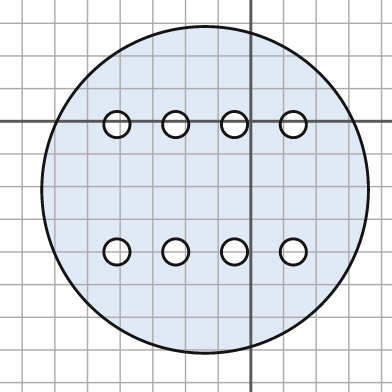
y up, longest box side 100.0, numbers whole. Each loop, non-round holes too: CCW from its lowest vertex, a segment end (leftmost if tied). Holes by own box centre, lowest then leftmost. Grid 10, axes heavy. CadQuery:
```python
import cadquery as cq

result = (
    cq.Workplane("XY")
    .moveTo(-14.0, -21.0)
    .circle(50.0)
    .moveTo(-41.0, -40.0)
    .circle(4.0)
    .moveTo(-23.0, -40.0)
    .circle(4.0)
    .moveTo(-5.0, -40.0)
    .circle(4.0)
    .moveTo(13.0, -40.0)
    .circle(4.0)
    .moveTo(-41.0, -1.0)
    .circle(4.0)
    .moveTo(-23.0, -1.0)
    .circle(4.0)
    .moveTo(-5.0, -1.0)
    .circle(4.0)
    .moveTo(13.0, -1.0)
    .circle(4.0)
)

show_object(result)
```